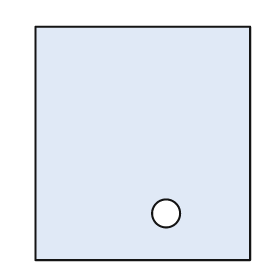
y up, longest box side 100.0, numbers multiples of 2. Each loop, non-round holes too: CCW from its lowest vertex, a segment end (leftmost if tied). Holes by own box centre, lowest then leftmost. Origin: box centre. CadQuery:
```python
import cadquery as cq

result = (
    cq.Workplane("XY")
    .moveTo(-46.0, -50.0)
    .lineTo(46.0, -50.0)
    .lineTo(46.0, 50.0)
    .lineTo(-46.0, 50.0)
    .close()
    .moveTo(10.0, -30.0)
    .circle(6.0)
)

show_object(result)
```